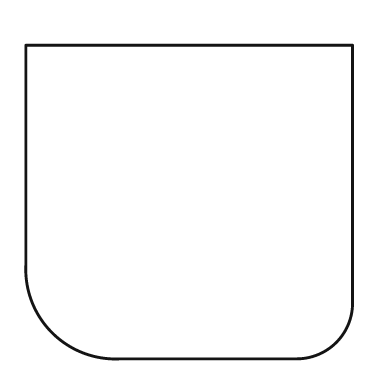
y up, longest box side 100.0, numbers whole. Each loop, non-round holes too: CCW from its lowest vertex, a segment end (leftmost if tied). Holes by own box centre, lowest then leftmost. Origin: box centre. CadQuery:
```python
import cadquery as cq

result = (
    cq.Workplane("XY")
    .moveTo(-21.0, -48.0)
    .lineTo(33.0, -48.0)
    .threePointArc((45.0, -43.0), (50.0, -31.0))
    .lineTo(50.0, 48.0)
    .lineTo(-50.0, 48.0)
    .lineTo(-50.0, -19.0)
    .threePointArc((-42.0, -40.0), (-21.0, -48.0))
    .close()
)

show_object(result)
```